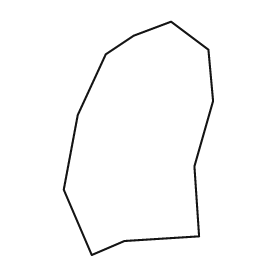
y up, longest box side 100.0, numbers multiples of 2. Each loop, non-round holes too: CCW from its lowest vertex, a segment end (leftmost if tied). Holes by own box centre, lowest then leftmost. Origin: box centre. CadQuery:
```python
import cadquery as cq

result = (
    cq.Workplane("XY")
    .moveTo(-20.0, -50.0)
    .lineTo(-6.0, -44.0)
    .lineTo(26.0, -42.0)
    .lineTo(24.0, -12.0)
    .lineTo(32.0, 16.0)
    .lineTo(30.0, 38.0)
    .lineTo(14.0, 50.0)
    .lineTo(-2.0, 44.0)
    .lineTo(-14.0, 36.0)
    .lineTo(-26.0, 10.0)
    .lineTo(-32.0, -22.0)
    .close()
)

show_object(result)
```